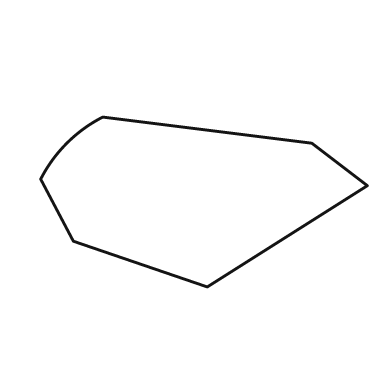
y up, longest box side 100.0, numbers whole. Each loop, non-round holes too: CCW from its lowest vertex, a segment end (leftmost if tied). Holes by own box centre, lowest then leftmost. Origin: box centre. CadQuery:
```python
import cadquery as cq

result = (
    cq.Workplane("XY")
    .moveTo(1.0, -26.0)
    .lineTo(50.0, 5.0)
    .lineTo(33.0, 18.0)
    .lineTo(-31.0, 26.0)
    .threePointArc((-42.0, 18.0), (-50.0, 7.0))
    .lineTo(-40.0, -12.0)
    .close()
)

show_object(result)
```